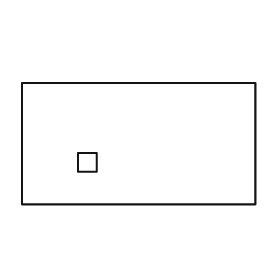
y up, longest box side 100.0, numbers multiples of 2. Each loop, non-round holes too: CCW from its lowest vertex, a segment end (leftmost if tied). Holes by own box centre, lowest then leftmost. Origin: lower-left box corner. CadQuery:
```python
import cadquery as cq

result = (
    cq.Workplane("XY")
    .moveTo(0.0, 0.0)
    .lineTo(100.0, 0.0)
    .lineTo(100.0, 52.0)
    .lineTo(0.0, 52.0)
    .close()
    .moveTo(24.0, 14.0)
    .lineTo(32.0, 14.0)
    .lineTo(32.0, 22.0)
    .lineTo(24.0, 22.0)
    .close()
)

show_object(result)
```